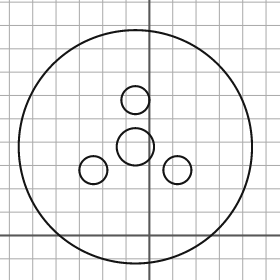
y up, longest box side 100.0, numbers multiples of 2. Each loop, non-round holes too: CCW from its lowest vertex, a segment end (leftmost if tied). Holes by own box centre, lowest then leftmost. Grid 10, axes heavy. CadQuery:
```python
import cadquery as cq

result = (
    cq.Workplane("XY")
    .moveTo(-6.0, 38.0)
    .circle(50.0)
    .moveTo(-24.0, 28.0)
    .circle(6.0)
    .moveTo(12.0, 28.0)
    .circle(6.0)
    .moveTo(-6.0, 38.0)
    .circle(8.0)
    .moveTo(-6.0, 58.0)
    .circle(6.0)
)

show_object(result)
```